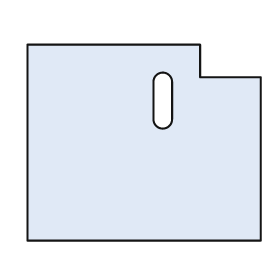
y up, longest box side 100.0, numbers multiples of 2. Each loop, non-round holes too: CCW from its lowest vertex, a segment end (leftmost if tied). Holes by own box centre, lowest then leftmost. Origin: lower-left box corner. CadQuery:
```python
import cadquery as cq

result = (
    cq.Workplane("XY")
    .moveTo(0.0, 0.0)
    .lineTo(100.0, 0.0)
    .lineTo(100.0, 70.0)
    .lineTo(74.0, 70.0)
    .lineTo(74.0, 84.0)
    .lineTo(0.0, 84.0)
    .close()
    .moveTo(54.0, 52.0)
    .threePointArc((58.0, 48.0), (62.0, 52.0))
    .lineTo(62.0, 68.0)
    .threePointArc((58.0, 72.0), (54.0, 68.0))
    .close()
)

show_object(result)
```